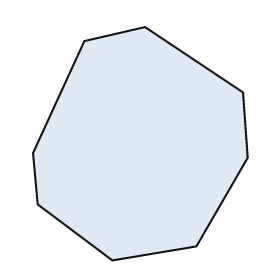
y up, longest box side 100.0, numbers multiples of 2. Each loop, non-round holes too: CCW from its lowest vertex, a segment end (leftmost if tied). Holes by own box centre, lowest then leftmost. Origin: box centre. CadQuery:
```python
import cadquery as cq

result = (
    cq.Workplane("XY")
    .moveTo(-12.0, -50.0)
    .lineTo(24.0, -44.0)
    .lineTo(46.0, -6.0)
    .lineTo(44.0, 22.0)
    .lineTo(2.0, 50.0)
    .lineTo(-24.0, 44.0)
    .lineTo(-46.0, -4.0)
    .lineTo(-44.0, -26.0)
    .close()
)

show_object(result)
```